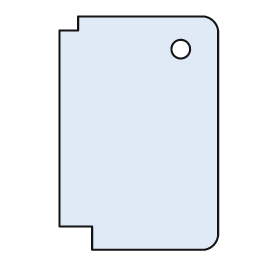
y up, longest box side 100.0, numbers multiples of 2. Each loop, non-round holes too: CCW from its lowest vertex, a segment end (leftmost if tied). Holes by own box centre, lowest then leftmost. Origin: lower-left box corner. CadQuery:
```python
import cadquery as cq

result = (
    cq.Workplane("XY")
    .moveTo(14.0, 0.0)
    .lineTo(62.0, 0.0)
    .threePointArc((66.0, 2.0), (68.0, 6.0))
    .lineTo(68.0, 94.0)
    .threePointArc((66.0, 98.0), (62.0, 100.0))
    .lineTo(8.0, 100.0)
    .lineTo(8.0, 94.0)
    .lineTo(0.0, 94.0)
    .lineTo(0.0, 10.0)
    .lineTo(14.0, 10.0)
    .close()
    .moveTo(52.0, 86.0)
    .circle(4.0)
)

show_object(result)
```